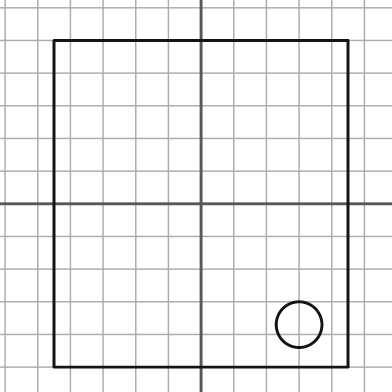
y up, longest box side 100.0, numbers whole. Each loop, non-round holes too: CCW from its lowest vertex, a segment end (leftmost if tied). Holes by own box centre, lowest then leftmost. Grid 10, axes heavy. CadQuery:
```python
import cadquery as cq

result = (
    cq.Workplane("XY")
    .moveTo(-45.0, -50.0)
    .lineTo(45.0, -50.0)
    .lineTo(45.0, 50.0)
    .lineTo(-45.0, 50.0)
    .close()
    .moveTo(30.0, -37.0)
    .circle(7.0)
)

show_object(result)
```